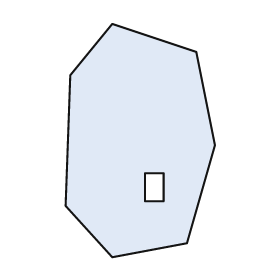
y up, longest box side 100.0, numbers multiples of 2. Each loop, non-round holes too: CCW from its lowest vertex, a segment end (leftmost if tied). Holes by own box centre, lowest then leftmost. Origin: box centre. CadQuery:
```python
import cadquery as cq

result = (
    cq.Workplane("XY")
    .moveTo(-12.0, -50.0)
    .lineTo(20.0, -44.0)
    .lineTo(32.0, -2.0)
    .lineTo(24.0, 38.0)
    .lineTo(-12.0, 50.0)
    .lineTo(-30.0, 28.0)
    .lineTo(-32.0, -28.0)
    .close()
    .moveTo(2.0, -26.0)
    .lineTo(10.0, -26.0)
    .lineTo(10.0, -14.0)
    .lineTo(2.0, -14.0)
    .close()
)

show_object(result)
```